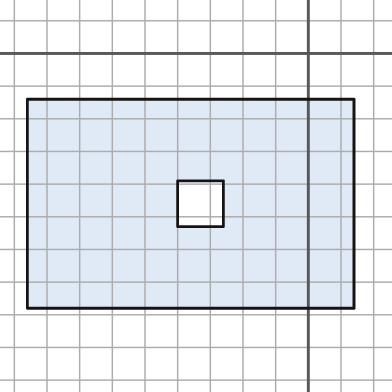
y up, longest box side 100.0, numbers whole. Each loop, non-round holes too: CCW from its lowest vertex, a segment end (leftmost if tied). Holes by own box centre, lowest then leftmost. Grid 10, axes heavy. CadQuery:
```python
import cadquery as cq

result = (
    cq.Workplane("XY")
    .moveTo(-86.0, -78.0)
    .lineTo(14.0, -78.0)
    .lineTo(14.0, -14.0)
    .lineTo(-86.0, -14.0)
    .close()
    .moveTo(-40.0, -53.0)
    .lineTo(-26.0, -53.0)
    .lineTo(-26.0, -39.0)
    .lineTo(-40.0, -39.0)
    .close()
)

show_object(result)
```